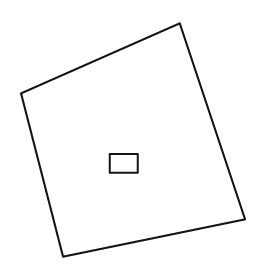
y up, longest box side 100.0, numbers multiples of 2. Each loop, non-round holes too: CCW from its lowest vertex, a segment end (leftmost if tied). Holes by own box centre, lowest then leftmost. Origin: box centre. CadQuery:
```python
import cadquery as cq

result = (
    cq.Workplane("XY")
    .moveTo(-30.0, -50.0)
    .lineTo(48.0, -34.0)
    .lineTo(20.0, 50.0)
    .lineTo(-48.0, 20.0)
    .close()
    .moveTo(-10.0, -14.0)
    .lineTo(2.0, -14.0)
    .lineTo(2.0, -6.0)
    .lineTo(-10.0, -6.0)
    .close()
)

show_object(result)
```